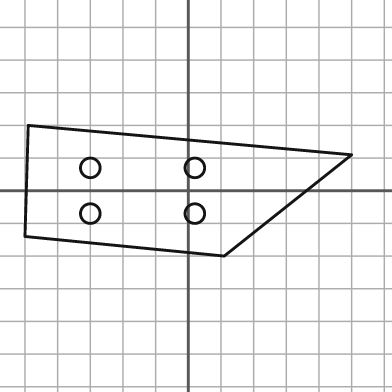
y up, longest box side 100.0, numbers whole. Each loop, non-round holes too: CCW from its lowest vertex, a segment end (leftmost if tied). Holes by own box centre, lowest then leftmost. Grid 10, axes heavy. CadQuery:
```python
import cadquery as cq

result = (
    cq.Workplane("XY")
    .moveTo(11.0, -20.0)
    .lineTo(50.0, 11.0)
    .lineTo(-49.0, 20.0)
    .lineTo(-50.0, -14.0)
    .close()
    .moveTo(-30.0, -7.0)
    .circle(3.0)
    .moveTo(2.0, -7.0)
    .circle(3.0)
    .moveTo(-30.0, 7.0)
    .circle(3.0)
    .moveTo(2.0, 7.0)
    .circle(3.0)
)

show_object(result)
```